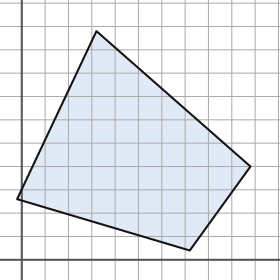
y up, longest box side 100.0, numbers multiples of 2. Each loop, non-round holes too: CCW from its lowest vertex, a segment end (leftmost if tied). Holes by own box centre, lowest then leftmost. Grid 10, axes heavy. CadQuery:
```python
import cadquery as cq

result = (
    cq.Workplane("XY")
    .moveTo(72.0, 4.0)
    .lineTo(98.0, 40.0)
    .lineTo(32.0, 98.0)
    .lineTo(-2.0, 26.0)
    .close()
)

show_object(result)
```